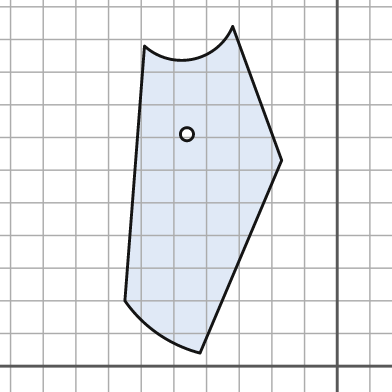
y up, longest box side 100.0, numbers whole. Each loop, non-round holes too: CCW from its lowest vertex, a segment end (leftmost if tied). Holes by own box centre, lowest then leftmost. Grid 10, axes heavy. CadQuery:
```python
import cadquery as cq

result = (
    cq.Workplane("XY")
    .moveTo(-42.0, 4.0)
    .lineTo(-17.0, 63.0)
    .lineTo(-32.0, 104.0)
    .threePointArc((-44.0, 94.0), (-59.0, 98.0))
    .lineTo(-65.0, 20.0)
    .threePointArc((-55.0, 10.0), (-42.0, 4.0))
    .close()
    .moveTo(-46.0, 71.0)
    .circle(2.0)
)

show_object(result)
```